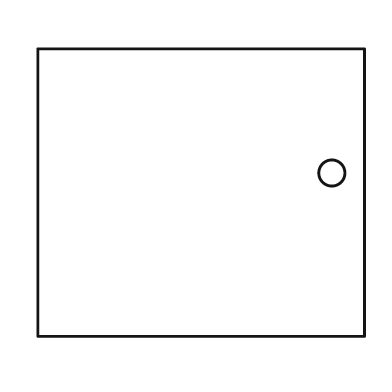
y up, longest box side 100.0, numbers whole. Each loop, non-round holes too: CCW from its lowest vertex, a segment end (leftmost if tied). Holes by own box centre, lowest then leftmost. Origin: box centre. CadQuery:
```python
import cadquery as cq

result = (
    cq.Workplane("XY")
    .moveTo(-50.0, -44.0)
    .lineTo(50.0, -44.0)
    .lineTo(50.0, 44.0)
    .lineTo(-50.0, 44.0)
    .close()
    .moveTo(40.0, 6.0)
    .circle(4.0)
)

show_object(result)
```